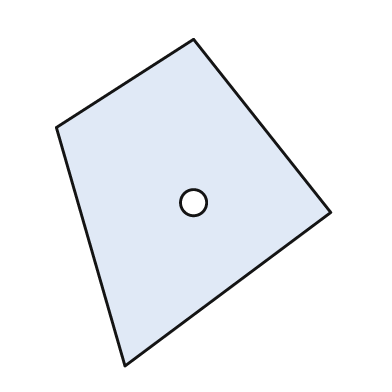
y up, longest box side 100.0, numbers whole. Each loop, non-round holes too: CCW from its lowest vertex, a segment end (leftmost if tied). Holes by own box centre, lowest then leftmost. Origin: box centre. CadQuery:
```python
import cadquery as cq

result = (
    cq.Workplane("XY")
    .moveTo(-21.0, -50.0)
    .lineTo(42.0, -3.0)
    .lineTo(0.0, 50.0)
    .lineTo(-42.0, 23.0)
    .close()
    .moveTo(0.0, 0.0)
    .circle(4.0)
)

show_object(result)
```